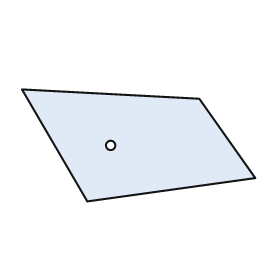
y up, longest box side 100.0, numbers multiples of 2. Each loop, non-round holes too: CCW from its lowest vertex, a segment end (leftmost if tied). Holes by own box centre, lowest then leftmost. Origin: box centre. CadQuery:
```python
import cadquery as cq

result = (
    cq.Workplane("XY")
    .moveTo(-22.0, -24.0)
    .lineTo(50.0, -14.0)
    .lineTo(26.0, 20.0)
    .lineTo(-50.0, 24.0)
    .close()
    .moveTo(-12.0, 0.0)
    .circle(2.0)
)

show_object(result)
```